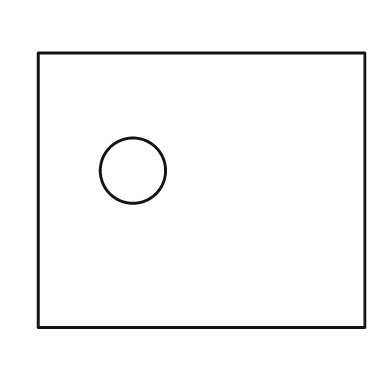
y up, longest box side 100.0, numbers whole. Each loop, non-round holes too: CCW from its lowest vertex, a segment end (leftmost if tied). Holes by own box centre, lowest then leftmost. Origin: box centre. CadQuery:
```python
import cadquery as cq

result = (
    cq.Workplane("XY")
    .moveTo(-50.0, -42.0)
    .lineTo(50.0, -42.0)
    .lineTo(50.0, 42.0)
    .lineTo(-50.0, 42.0)
    .close()
    .moveTo(-21.0, 6.0)
    .circle(10.0)
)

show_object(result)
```